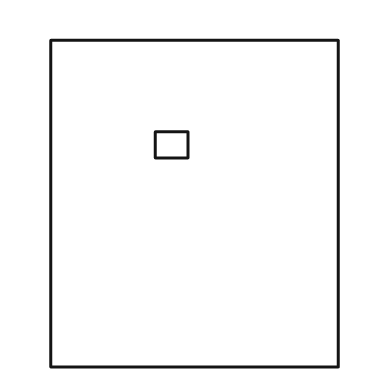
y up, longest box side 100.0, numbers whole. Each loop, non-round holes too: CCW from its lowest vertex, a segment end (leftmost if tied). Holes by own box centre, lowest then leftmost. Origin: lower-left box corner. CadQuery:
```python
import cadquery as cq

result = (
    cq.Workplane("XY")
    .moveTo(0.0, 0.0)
    .lineTo(88.0, 0.0)
    .lineTo(88.0, 100.0)
    .lineTo(0.0, 100.0)
    .close()
    .moveTo(32.0, 64.0)
    .lineTo(42.0, 64.0)
    .lineTo(42.0, 72.0)
    .lineTo(32.0, 72.0)
    .close()
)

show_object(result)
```